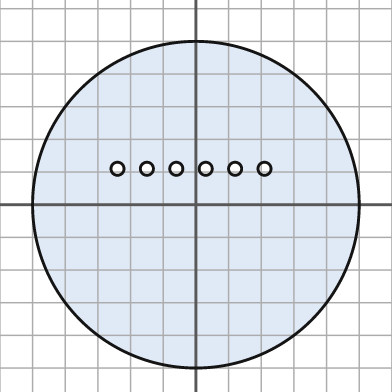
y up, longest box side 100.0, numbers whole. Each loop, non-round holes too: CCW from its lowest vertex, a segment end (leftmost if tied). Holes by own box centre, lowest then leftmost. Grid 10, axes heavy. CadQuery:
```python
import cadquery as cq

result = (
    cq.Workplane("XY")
    .moveTo(0.0, 0.0)
    .circle(50.0)
    .moveTo(-24.0, 11.0)
    .circle(2.0)
    .moveTo(-15.0, 11.0)
    .circle(2.0)
    .moveTo(-6.0, 11.0)
    .circle(2.0)
    .moveTo(3.0, 11.0)
    .circle(2.0)
    .moveTo(12.0, 11.0)
    .circle(2.0)
    .moveTo(21.0, 11.0)
    .circle(2.0)
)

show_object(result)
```